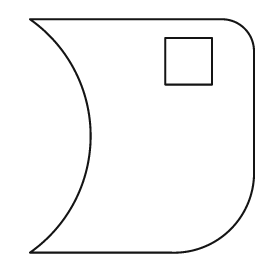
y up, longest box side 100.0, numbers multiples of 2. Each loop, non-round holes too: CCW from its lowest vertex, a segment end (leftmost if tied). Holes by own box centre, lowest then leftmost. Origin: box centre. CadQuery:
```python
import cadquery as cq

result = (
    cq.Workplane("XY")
    .moveTo(-48.0, -50.0)
    .lineTo(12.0, -50.0)
    .threePointArc((38.0, -40.0), (48.0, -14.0))
    .lineTo(48.0, 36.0)
    .threePointArc((44.0, 46.0), (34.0, 50.0))
    .lineTo(-48.0, 50.0)
    .threePointArc((-22.0, 0.0), (-48.0, -50.0))
    .close()
    .moveTo(10.0, 22.0)
    .lineTo(30.0, 22.0)
    .lineTo(30.0, 42.0)
    .lineTo(10.0, 42.0)
    .close()
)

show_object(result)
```